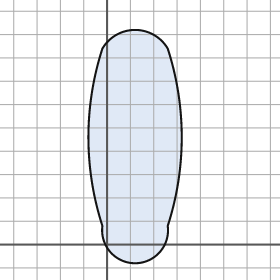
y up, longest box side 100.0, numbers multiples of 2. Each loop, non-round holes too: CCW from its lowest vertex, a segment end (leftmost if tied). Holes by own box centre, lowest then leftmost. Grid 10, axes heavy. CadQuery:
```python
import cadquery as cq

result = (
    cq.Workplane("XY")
    .moveTo(-2.0, 8.0)
    .threePointArc((12.0, -8.0), (26.0, 8.0))
    .threePointArc((32.0, 46.0), (26.0, 84.0))
    .threePointArc((12.0, 92.0), (-2.0, 84.0))
    .threePointArc((-8.0, 46.0), (-2.0, 8.0))
    .close()
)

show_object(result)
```